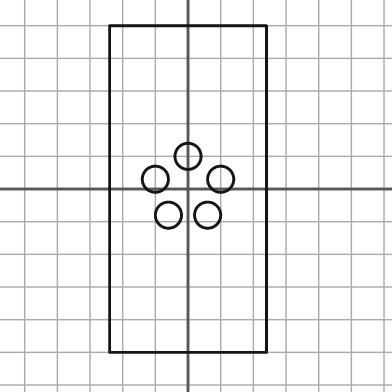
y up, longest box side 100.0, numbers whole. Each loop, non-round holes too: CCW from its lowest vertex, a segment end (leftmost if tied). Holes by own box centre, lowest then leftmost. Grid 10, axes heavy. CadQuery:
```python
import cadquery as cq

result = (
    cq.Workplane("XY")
    .moveTo(-24.0, -50.0)
    .lineTo(24.0, -50.0)
    .lineTo(24.0, 50.0)
    .lineTo(-24.0, 50.0)
    .close()
    .moveTo(-6.0, -8.0)
    .circle(4.0)
    .moveTo(6.0, -8.0)
    .circle(4.0)
    .moveTo(-10.0, 3.0)
    .circle(4.0)
    .moveTo(10.0, 3.0)
    .circle(4.0)
    .moveTo(0.0, 10.0)
    .circle(4.0)
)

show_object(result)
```